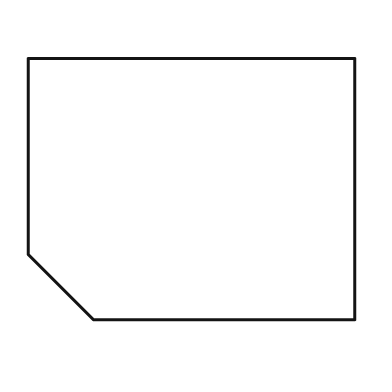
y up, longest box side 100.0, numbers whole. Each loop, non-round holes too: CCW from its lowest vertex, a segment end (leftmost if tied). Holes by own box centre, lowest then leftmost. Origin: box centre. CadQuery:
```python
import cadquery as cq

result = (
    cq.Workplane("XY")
    .moveTo(-30.0, -40.0)
    .lineTo(50.0, -40.0)
    .lineTo(50.0, 40.0)
    .lineTo(-50.0, 40.0)
    .lineTo(-50.0, -20.0)
    .close()
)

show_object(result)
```